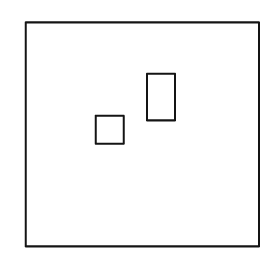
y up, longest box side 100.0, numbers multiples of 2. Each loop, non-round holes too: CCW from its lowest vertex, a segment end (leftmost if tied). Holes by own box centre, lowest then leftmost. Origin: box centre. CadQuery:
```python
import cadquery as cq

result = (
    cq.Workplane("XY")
    .moveTo(-50.0, -48.0)
    .lineTo(50.0, -48.0)
    .lineTo(50.0, 48.0)
    .lineTo(-50.0, 48.0)
    .close()
    .moveTo(-20.0, -4.0)
    .lineTo(-8.0, -4.0)
    .lineTo(-8.0, 8.0)
    .lineTo(-20.0, 8.0)
    .close()
    .moveTo(2.0, 6.0)
    .lineTo(14.0, 6.0)
    .lineTo(14.0, 26.0)
    .lineTo(2.0, 26.0)
    .close()
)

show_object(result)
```